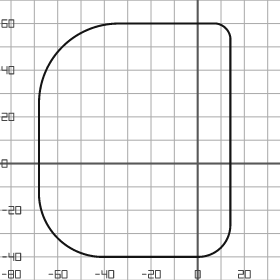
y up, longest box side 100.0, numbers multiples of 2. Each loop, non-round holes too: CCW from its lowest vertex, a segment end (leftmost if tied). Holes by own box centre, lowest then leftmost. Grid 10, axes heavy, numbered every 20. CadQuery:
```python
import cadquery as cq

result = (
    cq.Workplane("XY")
    .moveTo(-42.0, -40.0)
    .lineTo(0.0, -40.0)
    .threePointArc((10.0, -36.0), (14.0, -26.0))
    .lineTo(14.0, 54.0)
    .threePointArc((12.0, 58.0), (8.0, 60.0))
    .lineTo(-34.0, 60.0)
    .threePointArc((-58.0, 50.0), (-68.0, 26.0))
    .lineTo(-68.0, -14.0)
    .threePointArc((-60.0, -32.0), (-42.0, -40.0))
    .close()
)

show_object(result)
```